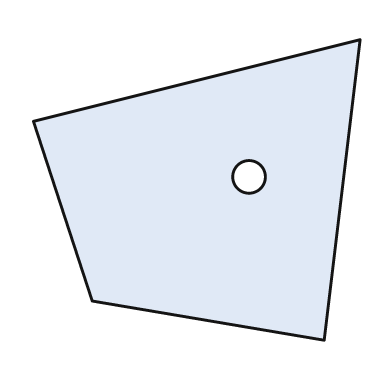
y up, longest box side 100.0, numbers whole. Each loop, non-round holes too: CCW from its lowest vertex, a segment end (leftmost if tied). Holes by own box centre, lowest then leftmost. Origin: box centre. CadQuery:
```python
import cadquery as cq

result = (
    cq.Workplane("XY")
    .moveTo(39.0, -46.0)
    .lineTo(50.0, 46.0)
    .lineTo(-50.0, 21.0)
    .lineTo(-32.0, -34.0)
    .close()
    .moveTo(16.0, 4.0)
    .circle(5.0)
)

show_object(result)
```